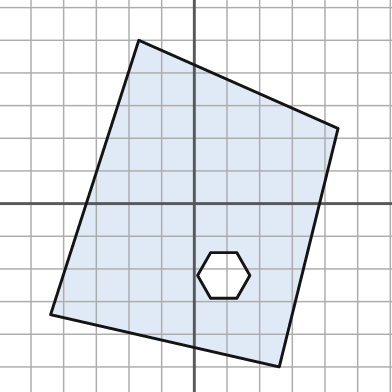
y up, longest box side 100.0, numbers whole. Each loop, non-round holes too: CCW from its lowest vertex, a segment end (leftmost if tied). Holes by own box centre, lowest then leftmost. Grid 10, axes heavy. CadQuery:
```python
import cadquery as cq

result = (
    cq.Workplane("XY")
    .moveTo(26.0, -50.0)
    .lineTo(44.0, 23.0)
    .lineTo(-17.0, 50.0)
    .lineTo(-44.0, -34.0)
    .close()
    .moveTo(5.0, -29.0)
    .lineTo(13.0, -29.0)
    .lineTo(17.0, -22.0)
    .lineTo(13.0, -15.0)
    .lineTo(5.0, -15.0)
    .lineTo(1.0, -22.0)
    .close()
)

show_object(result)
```